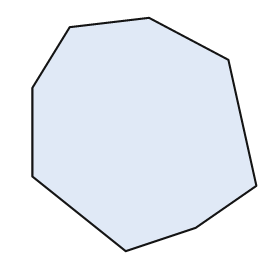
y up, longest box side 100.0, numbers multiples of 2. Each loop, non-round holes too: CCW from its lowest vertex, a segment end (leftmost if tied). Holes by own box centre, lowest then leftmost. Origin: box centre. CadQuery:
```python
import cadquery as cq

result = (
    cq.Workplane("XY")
    .moveTo(-8.0, -50.0)
    .lineTo(22.0, -40.0)
    .lineTo(48.0, -22.0)
    .lineTo(36.0, 32.0)
    .lineTo(2.0, 50.0)
    .lineTo(-32.0, 46.0)
    .lineTo(-48.0, 20.0)
    .lineTo(-48.0, -18.0)
    .close()
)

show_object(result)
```